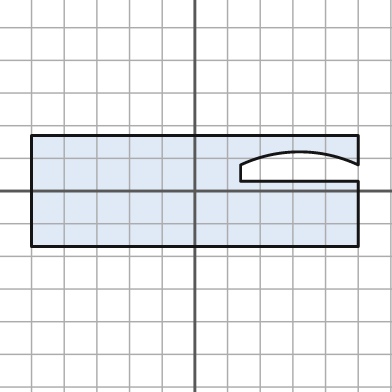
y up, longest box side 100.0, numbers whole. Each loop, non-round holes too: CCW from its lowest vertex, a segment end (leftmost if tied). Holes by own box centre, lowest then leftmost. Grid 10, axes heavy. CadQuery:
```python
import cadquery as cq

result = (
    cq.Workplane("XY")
    .moveTo(-50.0, -17.0)
    .lineTo(50.0, -17.0)
    .lineTo(50.0, 3.0)
    .lineTo(14.0, 3.0)
    .lineTo(14.0, 8.0)
    .threePointArc((32.0, 12.0), (50.0, 8.0))
    .lineTo(50.0, 17.0)
    .lineTo(-50.0, 17.0)
    .close()
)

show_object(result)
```